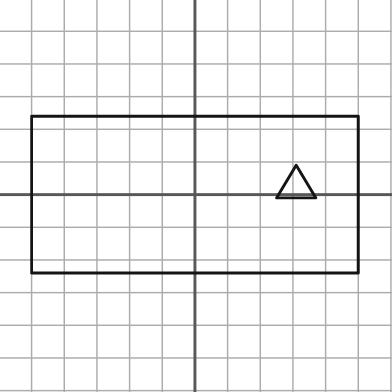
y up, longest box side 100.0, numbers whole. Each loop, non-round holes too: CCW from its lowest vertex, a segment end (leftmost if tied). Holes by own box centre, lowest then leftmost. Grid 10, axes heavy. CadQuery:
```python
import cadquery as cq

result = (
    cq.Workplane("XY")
    .moveTo(-50.0, -24.0)
    .lineTo(50.0, -24.0)
    .lineTo(50.0, 24.0)
    .lineTo(-50.0, 24.0)
    .close()
    .moveTo(25.0, -1.0)
    .lineTo(37.0, -1.0)
    .lineTo(31.0, 9.0)
    .close()
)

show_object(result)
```